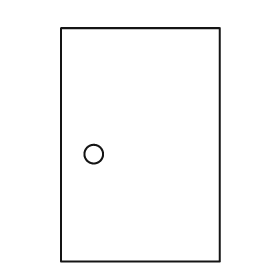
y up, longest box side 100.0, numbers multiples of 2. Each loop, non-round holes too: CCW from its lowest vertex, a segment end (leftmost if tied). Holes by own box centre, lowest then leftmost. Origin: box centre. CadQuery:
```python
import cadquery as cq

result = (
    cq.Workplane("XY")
    .moveTo(-34.0, -50.0)
    .lineTo(34.0, -50.0)
    .lineTo(34.0, 50.0)
    .lineTo(-34.0, 50.0)
    .close()
    .moveTo(-20.0, -4.0)
    .circle(4.0)
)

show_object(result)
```